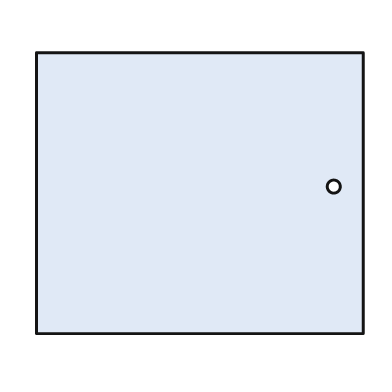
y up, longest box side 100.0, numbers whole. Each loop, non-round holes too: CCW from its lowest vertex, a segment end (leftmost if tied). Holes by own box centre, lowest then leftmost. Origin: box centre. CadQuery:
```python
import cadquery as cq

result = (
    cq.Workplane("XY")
    .moveTo(-50.0, -43.0)
    .lineTo(50.0, -43.0)
    .lineTo(50.0, 43.0)
    .lineTo(-50.0, 43.0)
    .close()
    .moveTo(41.0, 2.0)
    .circle(2.0)
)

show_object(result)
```